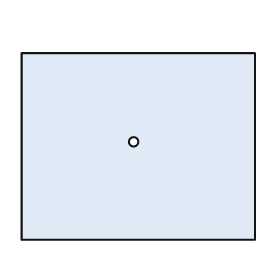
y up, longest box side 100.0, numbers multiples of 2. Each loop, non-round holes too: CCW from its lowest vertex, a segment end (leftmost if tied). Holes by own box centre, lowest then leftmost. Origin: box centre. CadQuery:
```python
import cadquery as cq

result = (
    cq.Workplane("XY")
    .moveTo(-50.0, -40.0)
    .lineTo(50.0, -40.0)
    .lineTo(50.0, 40.0)
    .lineTo(-50.0, 40.0)
    .close()
    .moveTo(-2.0, 2.0)
    .circle(2.0)
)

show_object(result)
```